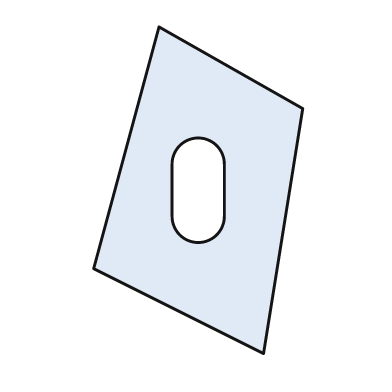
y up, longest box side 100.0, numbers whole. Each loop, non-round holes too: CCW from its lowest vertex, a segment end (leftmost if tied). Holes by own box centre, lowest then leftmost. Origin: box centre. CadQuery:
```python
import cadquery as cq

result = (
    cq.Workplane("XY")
    .moveTo(20.0, -50.0)
    .lineTo(32.0, 25.0)
    .lineTo(-12.0, 50.0)
    .lineTo(-32.0, -24.0)
    .close()
    .moveTo(-8.0, -8.0)
    .threePointArc((0.0, -16.0), (8.0, -8.0))
    .lineTo(8.0, 8.0)
    .threePointArc((0.0, 16.0), (-8.0, 8.0))
    .close()
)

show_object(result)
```